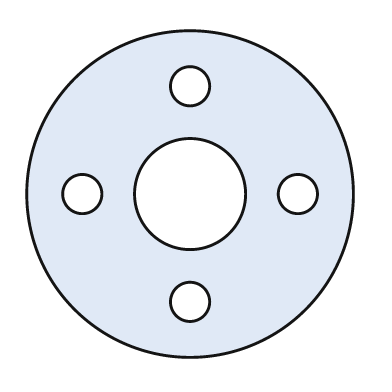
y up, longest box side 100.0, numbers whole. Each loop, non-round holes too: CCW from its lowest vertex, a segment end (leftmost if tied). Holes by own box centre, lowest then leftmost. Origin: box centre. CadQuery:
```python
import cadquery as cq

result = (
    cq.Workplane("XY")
    .moveTo(0.0, 0.0)
    .circle(50.0)
    .moveTo(0.0, -33.0)
    .circle(6.0)
    .moveTo(-33.0, 0.0)
    .circle(6.0)
    .moveTo(0.0, 0.0)
    .circle(17.0)
    .moveTo(33.0, 0.0)
    .circle(6.0)
    .moveTo(0.0, 33.0)
    .circle(6.0)
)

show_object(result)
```